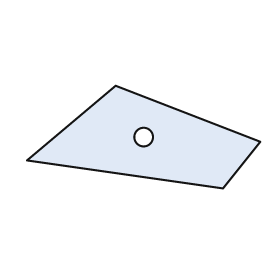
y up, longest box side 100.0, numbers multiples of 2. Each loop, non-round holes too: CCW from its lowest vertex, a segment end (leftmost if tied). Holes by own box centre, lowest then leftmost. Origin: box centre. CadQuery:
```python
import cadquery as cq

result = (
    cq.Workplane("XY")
    .moveTo(34.0, -22.0)
    .lineTo(50.0, -2.0)
    .lineTo(-12.0, 22.0)
    .lineTo(-50.0, -10.0)
    .close()
    .moveTo(0.0, 0.0)
    .circle(4.0)
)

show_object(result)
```